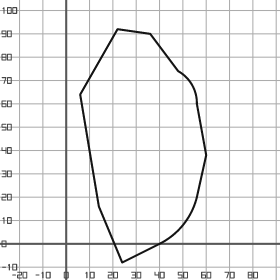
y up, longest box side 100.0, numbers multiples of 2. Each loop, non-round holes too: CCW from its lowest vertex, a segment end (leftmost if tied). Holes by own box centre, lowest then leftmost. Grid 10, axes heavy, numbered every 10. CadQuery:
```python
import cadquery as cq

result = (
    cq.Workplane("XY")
    .moveTo(24.0, -8.0)
    .lineTo(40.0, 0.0)
    .threePointArc((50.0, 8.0), (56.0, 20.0))
    .lineTo(60.0, 38.0)
    .lineTo(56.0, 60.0)
    .threePointArc((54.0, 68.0), (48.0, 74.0))
    .lineTo(36.0, 90.0)
    .lineTo(22.0, 92.0)
    .lineTo(6.0, 64.0)
    .lineTo(14.0, 16.0)
    .close()
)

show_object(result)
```